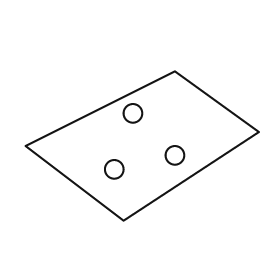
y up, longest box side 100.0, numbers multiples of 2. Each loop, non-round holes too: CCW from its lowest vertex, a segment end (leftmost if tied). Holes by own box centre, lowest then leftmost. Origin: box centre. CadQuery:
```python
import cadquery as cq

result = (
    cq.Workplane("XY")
    .moveTo(-8.0, -32.0)
    .lineTo(50.0, 6.0)
    .lineTo(14.0, 32.0)
    .lineTo(-50.0, 0.0)
    .close()
    .moveTo(-12.0, -10.0)
    .circle(4.0)
    .moveTo(14.0, -4.0)
    .circle(4.0)
    .moveTo(-4.0, 14.0)
    .circle(4.0)
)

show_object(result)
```